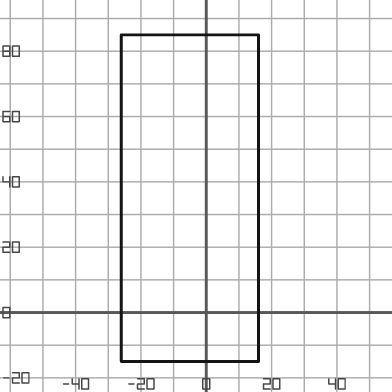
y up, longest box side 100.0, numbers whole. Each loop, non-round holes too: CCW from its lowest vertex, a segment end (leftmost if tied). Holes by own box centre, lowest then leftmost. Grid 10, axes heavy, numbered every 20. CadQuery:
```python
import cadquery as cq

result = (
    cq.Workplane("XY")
    .moveTo(-26.0, -15.0)
    .lineTo(16.0, -15.0)
    .lineTo(16.0, 85.0)
    .lineTo(-26.0, 85.0)
    .close()
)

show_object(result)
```